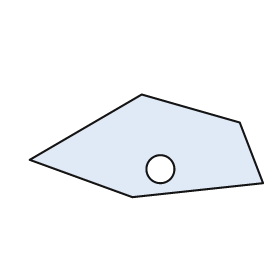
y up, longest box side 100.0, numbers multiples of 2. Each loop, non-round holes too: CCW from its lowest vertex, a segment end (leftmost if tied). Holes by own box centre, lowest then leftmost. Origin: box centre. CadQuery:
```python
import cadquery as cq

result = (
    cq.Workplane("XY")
    .moveTo(-6.0, -22.0)
    .lineTo(50.0, -16.0)
    .lineTo(40.0, 10.0)
    .lineTo(-2.0, 22.0)
    .lineTo(-50.0, -6.0)
    .close()
    .moveTo(6.0, -10.0)
    .circle(6.0)
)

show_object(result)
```